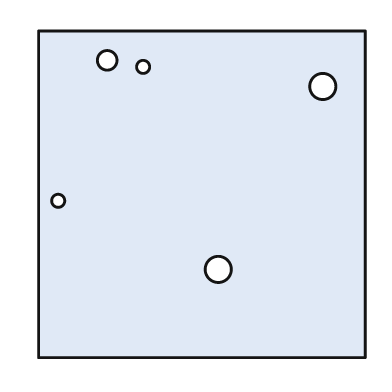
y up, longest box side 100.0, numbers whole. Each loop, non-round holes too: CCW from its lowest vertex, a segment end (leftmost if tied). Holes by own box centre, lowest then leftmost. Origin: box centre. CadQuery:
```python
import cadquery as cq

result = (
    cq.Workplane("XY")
    .moveTo(-50.0, -50.0)
    .lineTo(50.0, -50.0)
    .lineTo(50.0, 50.0)
    .lineTo(-50.0, 50.0)
    .close()
    .moveTo(5.0, -23.0)
    .circle(4.0)
    .moveTo(-44.0, -2.0)
    .circle(2.0)
    .moveTo(37.0, 33.0)
    .circle(4.0)
    .moveTo(-18.0, 39.0)
    .circle(2.0)
    .moveTo(-29.0, 41.0)
    .circle(3.0)
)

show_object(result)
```